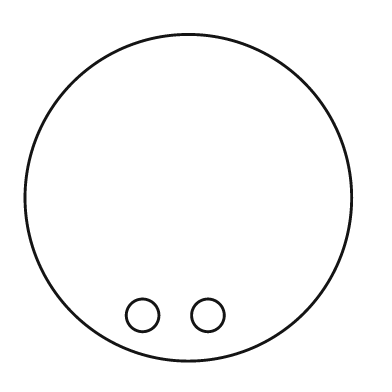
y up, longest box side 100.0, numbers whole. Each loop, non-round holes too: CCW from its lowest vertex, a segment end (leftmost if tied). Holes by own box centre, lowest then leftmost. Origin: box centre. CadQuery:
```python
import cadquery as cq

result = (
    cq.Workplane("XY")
    .moveTo(0.0, 0.0)
    .circle(50.0)
    .moveTo(-14.0, -36.0)
    .circle(5.0)
    .moveTo(6.0, -36.0)
    .circle(5.0)
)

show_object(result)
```